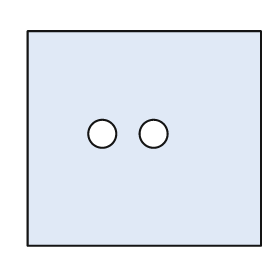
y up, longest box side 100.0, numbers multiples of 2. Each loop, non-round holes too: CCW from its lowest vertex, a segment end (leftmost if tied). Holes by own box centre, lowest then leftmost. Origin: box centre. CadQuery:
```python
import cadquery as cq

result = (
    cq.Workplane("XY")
    .moveTo(-50.0, -46.0)
    .lineTo(50.0, -46.0)
    .lineTo(50.0, 46.0)
    .lineTo(-50.0, 46.0)
    .close()
    .moveTo(-18.0, 2.0)
    .circle(6.0)
    .moveTo(4.0, 2.0)
    .circle(6.0)
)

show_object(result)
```